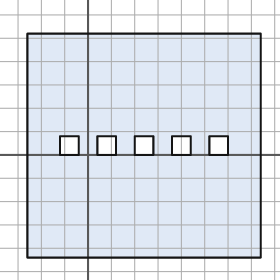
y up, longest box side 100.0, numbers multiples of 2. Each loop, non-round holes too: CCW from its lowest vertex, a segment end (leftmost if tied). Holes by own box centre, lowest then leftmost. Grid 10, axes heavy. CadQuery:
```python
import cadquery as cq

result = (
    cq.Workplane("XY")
    .moveTo(-26.0, -44.0)
    .lineTo(74.0, -44.0)
    .lineTo(74.0, 52.0)
    .lineTo(-26.0, 52.0)
    .close()
    .moveTo(-12.0, 0.0)
    .lineTo(-4.0, 0.0)
    .lineTo(-4.0, 8.0)
    .lineTo(-12.0, 8.0)
    .close()
    .moveTo(4.0, 0.0)
    .lineTo(12.0, 0.0)
    .lineTo(12.0, 8.0)
    .lineTo(4.0, 8.0)
    .close()
    .moveTo(20.0, 0.0)
    .lineTo(28.0, 0.0)
    .lineTo(28.0, 8.0)
    .lineTo(20.0, 8.0)
    .close()
    .moveTo(36.0, 0.0)
    .lineTo(44.0, 0.0)
    .lineTo(44.0, 8.0)
    .lineTo(36.0, 8.0)
    .close()
    .moveTo(52.0, 0.0)
    .lineTo(60.0, 0.0)
    .lineTo(60.0, 8.0)
    .lineTo(52.0, 8.0)
    .close()
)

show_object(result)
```